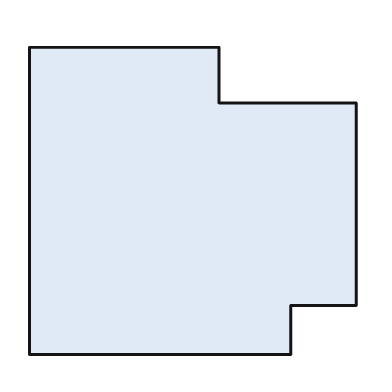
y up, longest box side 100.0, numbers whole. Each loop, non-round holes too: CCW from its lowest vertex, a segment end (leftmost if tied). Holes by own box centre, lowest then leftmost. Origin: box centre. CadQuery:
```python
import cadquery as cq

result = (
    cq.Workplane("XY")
    .moveTo(-50.0, -47.0)
    .lineTo(30.0, -47.0)
    .lineTo(30.0, -32.0)
    .lineTo(50.0, -32.0)
    .lineTo(50.0, 30.0)
    .lineTo(8.0, 30.0)
    .lineTo(8.0, 47.0)
    .lineTo(-50.0, 47.0)
    .close()
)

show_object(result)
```